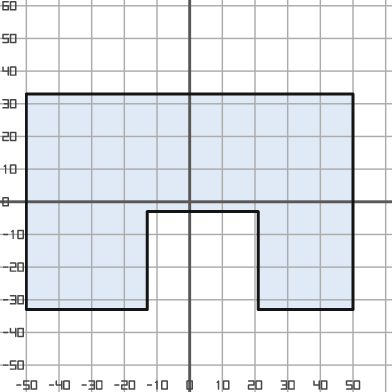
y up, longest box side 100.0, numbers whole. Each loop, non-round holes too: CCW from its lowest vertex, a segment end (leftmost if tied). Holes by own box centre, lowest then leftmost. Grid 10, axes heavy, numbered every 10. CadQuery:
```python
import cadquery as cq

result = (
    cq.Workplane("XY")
    .moveTo(-50.0, -33.0)
    .lineTo(-13.0, -33.0)
    .lineTo(-13.0, -3.0)
    .lineTo(21.0, -3.0)
    .lineTo(21.0, -33.0)
    .lineTo(50.0, -33.0)
    .lineTo(50.0, 33.0)
    .lineTo(-50.0, 33.0)
    .close()
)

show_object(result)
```